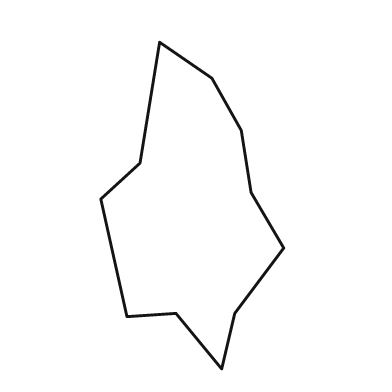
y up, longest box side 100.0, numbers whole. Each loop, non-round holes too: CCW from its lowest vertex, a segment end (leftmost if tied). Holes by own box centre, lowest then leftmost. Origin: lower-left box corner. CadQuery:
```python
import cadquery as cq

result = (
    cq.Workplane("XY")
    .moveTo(37.0, 0.0)
    .lineTo(41.0, 17.0)
    .lineTo(56.0, 37.0)
    .lineTo(46.0, 54.0)
    .lineTo(43.0, 73.0)
    .lineTo(34.0, 89.0)
    .lineTo(18.0, 100.0)
    .lineTo(12.0, 63.0)
    .lineTo(0.0, 52.0)
    .lineTo(8.0, 16.0)
    .lineTo(23.0, 17.0)
    .close()
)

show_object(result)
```